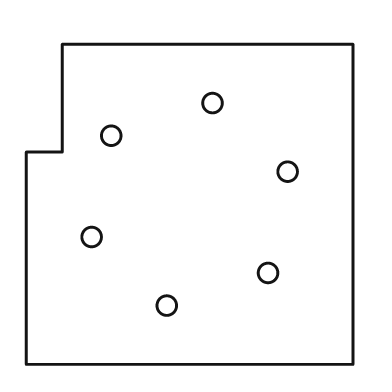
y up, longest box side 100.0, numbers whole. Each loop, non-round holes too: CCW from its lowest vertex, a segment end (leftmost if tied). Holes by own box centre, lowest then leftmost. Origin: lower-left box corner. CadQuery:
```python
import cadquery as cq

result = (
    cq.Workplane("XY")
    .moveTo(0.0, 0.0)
    .lineTo(100.0, 0.0)
    .lineTo(100.0, 98.0)
    .lineTo(11.0, 98.0)
    .lineTo(11.0, 65.0)
    .lineTo(0.0, 65.0)
    .close()
    .moveTo(43.0, 18.0)
    .circle(3.0)
    .moveTo(74.0, 28.0)
    .circle(3.0)
    .moveTo(20.0, 39.0)
    .circle(3.0)
    .moveTo(80.0, 59.0)
    .circle(3.0)
    .moveTo(26.0, 70.0)
    .circle(3.0)
    .moveTo(57.0, 80.0)
    .circle(3.0)
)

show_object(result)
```